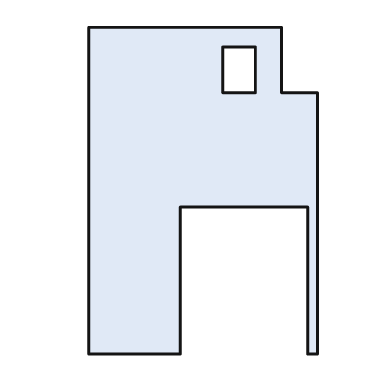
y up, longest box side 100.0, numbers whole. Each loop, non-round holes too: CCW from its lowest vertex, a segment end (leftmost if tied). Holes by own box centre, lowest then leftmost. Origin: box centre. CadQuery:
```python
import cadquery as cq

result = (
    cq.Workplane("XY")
    .moveTo(-35.0, -50.0)
    .lineTo(-7.0, -50.0)
    .lineTo(-7.0, -5.0)
    .lineTo(32.0, -5.0)
    .lineTo(32.0, -50.0)
    .lineTo(35.0, -50.0)
    .lineTo(35.0, 30.0)
    .lineTo(24.0, 30.0)
    .lineTo(24.0, 50.0)
    .lineTo(-35.0, 50.0)
    .close()
    .moveTo(6.0, 30.0)
    .lineTo(16.0, 30.0)
    .lineTo(16.0, 44.0)
    .lineTo(6.0, 44.0)
    .close()
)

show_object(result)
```